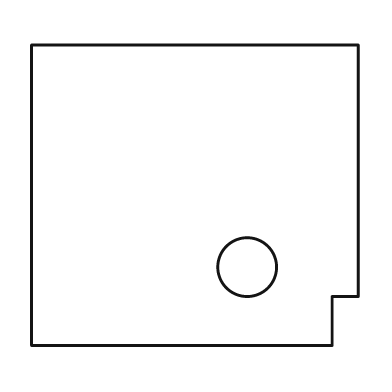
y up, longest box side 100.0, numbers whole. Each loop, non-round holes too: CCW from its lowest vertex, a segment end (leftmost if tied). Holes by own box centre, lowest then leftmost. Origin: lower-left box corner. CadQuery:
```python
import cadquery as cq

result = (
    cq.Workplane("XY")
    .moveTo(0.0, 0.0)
    .lineTo(92.0, 0.0)
    .lineTo(92.0, 15.0)
    .lineTo(100.0, 15.0)
    .lineTo(100.0, 92.0)
    .lineTo(0.0, 92.0)
    .close()
    .moveTo(66.0, 24.0)
    .circle(9.0)
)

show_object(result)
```